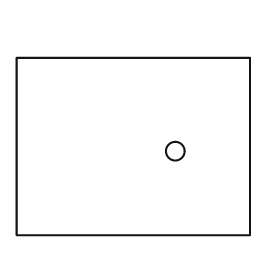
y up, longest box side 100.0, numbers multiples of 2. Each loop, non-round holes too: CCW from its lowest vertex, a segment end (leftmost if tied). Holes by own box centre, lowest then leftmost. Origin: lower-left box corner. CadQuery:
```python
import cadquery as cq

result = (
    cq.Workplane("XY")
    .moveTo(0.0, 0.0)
    .lineTo(100.0, 0.0)
    .lineTo(100.0, 76.0)
    .lineTo(0.0, 76.0)
    .close()
    .moveTo(68.0, 36.0)
    .circle(4.0)
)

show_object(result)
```